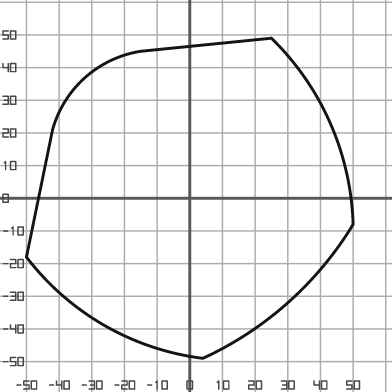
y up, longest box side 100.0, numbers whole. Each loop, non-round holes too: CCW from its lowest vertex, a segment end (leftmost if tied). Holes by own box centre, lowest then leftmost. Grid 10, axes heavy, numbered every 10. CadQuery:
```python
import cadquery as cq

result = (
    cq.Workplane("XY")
    .moveTo(4.0, -49.0)
    .threePointArc((30.0, -32.0), (50.0, -8.0))
    .threePointArc((43.0, 23.0), (25.0, 49.0))
    .lineTo(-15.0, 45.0)
    .threePointArc((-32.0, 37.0), (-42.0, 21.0))
    .lineTo(-50.0, -18.0)
    .threePointArc((-26.0, -39.0), (4.0, -49.0))
    .close()
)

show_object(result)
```